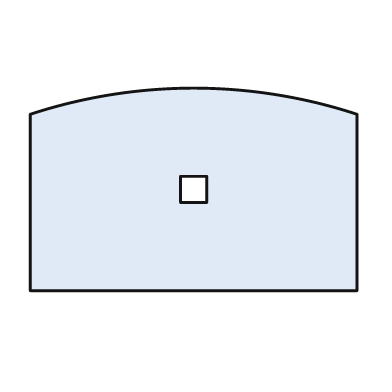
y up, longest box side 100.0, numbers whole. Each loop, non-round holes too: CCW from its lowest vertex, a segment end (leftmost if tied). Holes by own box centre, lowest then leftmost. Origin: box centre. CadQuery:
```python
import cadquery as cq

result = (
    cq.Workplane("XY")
    .moveTo(-50.0, -31.0)
    .lineTo(50.0, -31.0)
    .lineTo(50.0, 23.0)
    .threePointArc((0.0, 31.0), (-50.0, 23.0))
    .close()
    .moveTo(-4.0, -4.0)
    .lineTo(4.0, -4.0)
    .lineTo(4.0, 4.0)
    .lineTo(-4.0, 4.0)
    .close()
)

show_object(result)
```